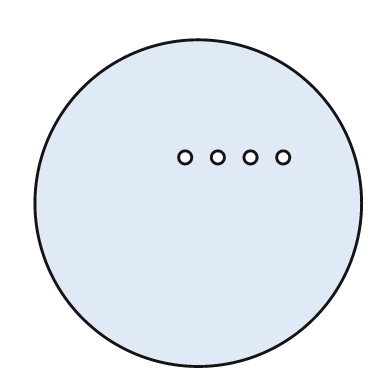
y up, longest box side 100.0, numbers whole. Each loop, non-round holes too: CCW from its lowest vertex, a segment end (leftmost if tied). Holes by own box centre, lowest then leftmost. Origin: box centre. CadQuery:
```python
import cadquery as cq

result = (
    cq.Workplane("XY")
    .moveTo(0.0, 0.0)
    .circle(50.0)
    .moveTo(-4.0, 14.0)
    .circle(2.0)
    .moveTo(6.0, 14.0)
    .circle(2.0)
    .moveTo(16.0, 14.0)
    .circle(2.0)
    .moveTo(26.0, 14.0)
    .circle(2.0)
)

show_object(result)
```